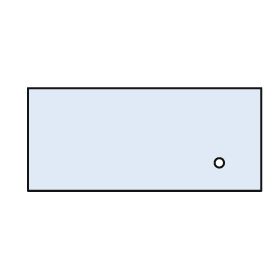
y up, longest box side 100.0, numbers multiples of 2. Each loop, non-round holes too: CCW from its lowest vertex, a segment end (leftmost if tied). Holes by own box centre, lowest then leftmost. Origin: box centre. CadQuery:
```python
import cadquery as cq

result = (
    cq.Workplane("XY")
    .moveTo(-50.0, -22.0)
    .lineTo(50.0, -22.0)
    .lineTo(50.0, 22.0)
    .lineTo(-50.0, 22.0)
    .close()
    .moveTo(32.0, -10.0)
    .circle(2.0)
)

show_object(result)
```